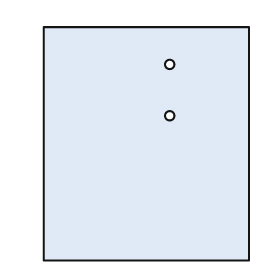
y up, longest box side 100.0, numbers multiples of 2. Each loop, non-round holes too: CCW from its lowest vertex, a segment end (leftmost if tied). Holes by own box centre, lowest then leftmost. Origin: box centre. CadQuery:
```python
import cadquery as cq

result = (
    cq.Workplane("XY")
    .moveTo(-44.0, -50.0)
    .lineTo(44.0, -50.0)
    .lineTo(44.0, 50.0)
    .lineTo(-44.0, 50.0)
    .close()
    .moveTo(10.0, 12.0)
    .circle(2.0)
    .moveTo(10.0, 34.0)
    .circle(2.0)
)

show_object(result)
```